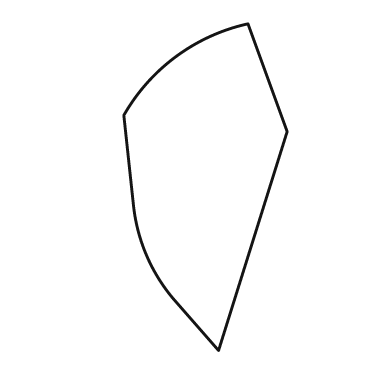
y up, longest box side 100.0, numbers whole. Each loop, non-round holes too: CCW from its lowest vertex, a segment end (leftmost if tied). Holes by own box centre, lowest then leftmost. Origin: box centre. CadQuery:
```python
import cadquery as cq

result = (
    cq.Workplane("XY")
    .moveTo(4.0, -50.0)
    .lineTo(25.0, 17.0)
    .lineTo(13.0, 50.0)
    .threePointArc((-9.0, 40.0), (-25.0, 22.0))
    .lineTo(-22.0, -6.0)
    .threePointArc((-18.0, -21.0), (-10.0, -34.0))
    .close()
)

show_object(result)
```